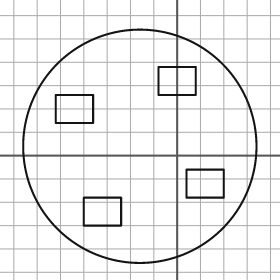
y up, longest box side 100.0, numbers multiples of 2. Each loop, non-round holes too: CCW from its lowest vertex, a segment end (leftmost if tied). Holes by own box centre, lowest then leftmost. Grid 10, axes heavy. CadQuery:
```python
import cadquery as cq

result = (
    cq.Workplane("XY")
    .moveTo(-16.0, 4.0)
    .circle(50.0)
    .moveTo(-40.0, -30.0)
    .lineTo(-24.0, -30.0)
    .lineTo(-24.0, -18.0)
    .lineTo(-40.0, -18.0)
    .close()
    .moveTo(4.0, -18.0)
    .lineTo(20.0, -18.0)
    .lineTo(20.0, -6.0)
    .lineTo(4.0, -6.0)
    .close()
    .moveTo(-52.0, 14.0)
    .lineTo(-36.0, 14.0)
    .lineTo(-36.0, 26.0)
    .lineTo(-52.0, 26.0)
    .close()
    .moveTo(-8.0, 26.0)
    .lineTo(8.0, 26.0)
    .lineTo(8.0, 38.0)
    .lineTo(-8.0, 38.0)
    .close()
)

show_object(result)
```